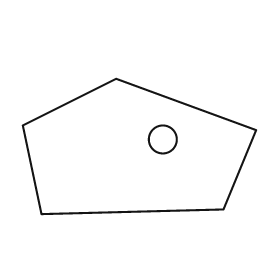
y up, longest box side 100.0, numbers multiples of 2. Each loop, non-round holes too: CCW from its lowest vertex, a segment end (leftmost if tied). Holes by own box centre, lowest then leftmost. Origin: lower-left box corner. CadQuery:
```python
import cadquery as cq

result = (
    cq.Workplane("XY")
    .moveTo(8.0, 0.0)
    .lineTo(86.0, 2.0)
    .lineTo(100.0, 36.0)
    .lineTo(40.0, 58.0)
    .lineTo(0.0, 38.0)
    .close()
    .moveTo(60.0, 32.0)
    .circle(6.0)
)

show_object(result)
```